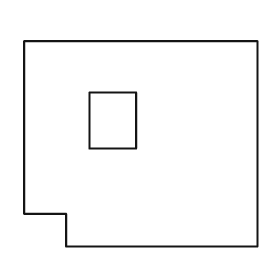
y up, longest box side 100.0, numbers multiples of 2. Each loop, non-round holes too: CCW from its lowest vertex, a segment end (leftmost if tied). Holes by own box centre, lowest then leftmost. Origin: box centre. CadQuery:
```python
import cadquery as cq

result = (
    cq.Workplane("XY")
    .moveTo(-32.0, -44.0)
    .lineTo(50.0, -44.0)
    .lineTo(50.0, 44.0)
    .lineTo(-50.0, 44.0)
    .lineTo(-50.0, -30.0)
    .lineTo(-32.0, -30.0)
    .close()
    .moveTo(-22.0, -2.0)
    .lineTo(-2.0, -2.0)
    .lineTo(-2.0, 22.0)
    .lineTo(-22.0, 22.0)
    .close()
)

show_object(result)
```